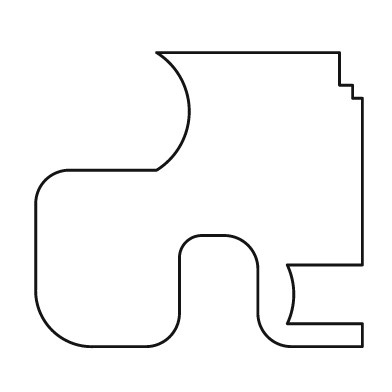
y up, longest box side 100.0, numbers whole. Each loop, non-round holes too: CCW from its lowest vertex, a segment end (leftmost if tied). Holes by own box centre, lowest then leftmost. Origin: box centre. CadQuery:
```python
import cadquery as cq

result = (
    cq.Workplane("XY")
    .moveTo(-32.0, -45.0)
    .lineTo(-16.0, -45.0)
    .threePointArc((-9.0, -42.0), (-6.0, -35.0))
    .lineTo(-6.0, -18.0)
    .threePointArc((-4.0, -13.0), (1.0, -11.0))
    .lineTo(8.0, -11.0)
    .threePointArc((15.0, -14.0), (18.0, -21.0))
    .lineTo(18.0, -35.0)
    .threePointArc((21.0, -42.0), (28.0, -45.0))
    .lineTo(50.0, -45.0)
    .lineTo(50.0, -38.0)
    .lineTo(27.0, -38.0)
    .threePointArc((29.0, -29.0), (27.0, -20.0))
    .lineTo(50.0, -20.0)
    .lineTo(50.0, 31.0)
    .lineTo(47.0, 31.0)
    .lineTo(47.0, 35.0)
    .lineTo(43.0, 35.0)
    .lineTo(43.0, 45.0)
    .lineTo(-13.0, 45.0)
    .threePointArc((-3.0, 27.0), (-13.0, 9.0))
    .lineTo(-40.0, 9.0)
    .threePointArc((-47.0, 6.0), (-50.0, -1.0))
    .lineTo(-50.0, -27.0)
    .threePointArc((-45.0, -40.0), (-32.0, -45.0))
    .close()
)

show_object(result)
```